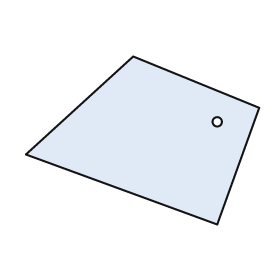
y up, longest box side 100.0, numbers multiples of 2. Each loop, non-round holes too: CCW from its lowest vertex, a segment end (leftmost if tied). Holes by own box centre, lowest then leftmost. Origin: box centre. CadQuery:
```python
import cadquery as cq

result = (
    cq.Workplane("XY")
    .moveTo(32.0, -36.0)
    .lineTo(50.0, 14.0)
    .lineTo(-4.0, 36.0)
    .lineTo(-50.0, -6.0)
    .close()
    .moveTo(32.0, 8.0)
    .circle(2.0)
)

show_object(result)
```